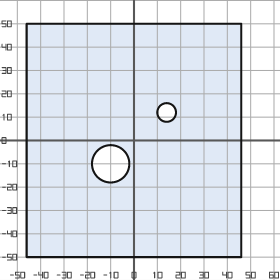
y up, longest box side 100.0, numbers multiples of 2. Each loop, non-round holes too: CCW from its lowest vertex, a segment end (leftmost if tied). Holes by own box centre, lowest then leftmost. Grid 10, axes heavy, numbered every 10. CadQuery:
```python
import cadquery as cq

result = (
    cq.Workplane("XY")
    .moveTo(-46.0, -50.0)
    .lineTo(46.0, -50.0)
    .lineTo(46.0, 50.0)
    .lineTo(-46.0, 50.0)
    .close()
    .moveTo(-10.0, -10.0)
    .circle(8.0)
    .moveTo(14.0, 12.0)
    .circle(4.0)
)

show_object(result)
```